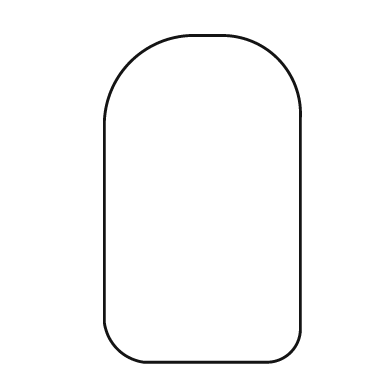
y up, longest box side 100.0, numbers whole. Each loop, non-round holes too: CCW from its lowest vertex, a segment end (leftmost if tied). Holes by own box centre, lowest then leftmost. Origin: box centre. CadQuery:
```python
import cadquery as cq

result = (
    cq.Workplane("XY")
    .moveTo(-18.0, -50.0)
    .lineTo(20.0, -50.0)
    .threePointArc((27.0, -47.0), (30.0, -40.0))
    .lineTo(30.0, 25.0)
    .threePointArc((23.0, 43.0), (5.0, 50.0))
    .lineTo(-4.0, 50.0)
    .threePointArc((-22.0, 42.0), (-30.0, 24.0))
    .lineTo(-30.0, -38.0)
    .threePointArc((-26.0, -46.0), (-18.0, -50.0))
    .close()
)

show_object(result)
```